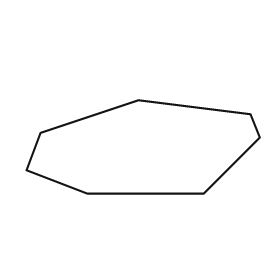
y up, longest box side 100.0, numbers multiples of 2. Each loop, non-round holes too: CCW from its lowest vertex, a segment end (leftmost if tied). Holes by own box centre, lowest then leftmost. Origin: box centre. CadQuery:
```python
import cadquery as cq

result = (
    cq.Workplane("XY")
    .moveTo(-24.0, -20.0)
    .lineTo(26.0, -20.0)
    .lineTo(50.0, 4.0)
    .lineTo(46.0, 14.0)
    .lineTo(-2.0, 20.0)
    .lineTo(-44.0, 6.0)
    .lineTo(-50.0, -10.0)
    .close()
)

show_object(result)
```